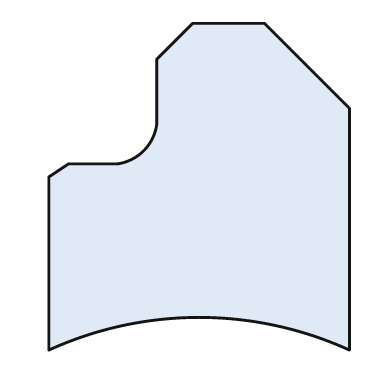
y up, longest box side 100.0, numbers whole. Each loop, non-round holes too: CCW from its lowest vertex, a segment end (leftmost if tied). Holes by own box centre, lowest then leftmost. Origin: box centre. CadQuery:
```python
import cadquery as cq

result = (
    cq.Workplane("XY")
    .moveTo(-46.0, -50.0)
    .threePointArc((0.0, -40.0), (46.0, -50.0))
    .lineTo(46.0, 24.0)
    .lineTo(20.0, 50.0)
    .lineTo(-2.0, 50.0)
    .lineTo(-13.0, 39.0)
    .lineTo(-13.0, 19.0)
    .threePointArc((-17.0, 11.0), (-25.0, 7.0))
    .lineTo(-40.0, 7.0)
    .lineTo(-46.0, 3.0)
    .close()
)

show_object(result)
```